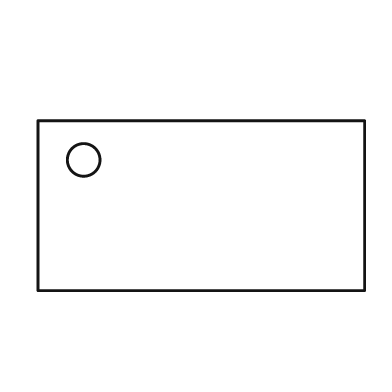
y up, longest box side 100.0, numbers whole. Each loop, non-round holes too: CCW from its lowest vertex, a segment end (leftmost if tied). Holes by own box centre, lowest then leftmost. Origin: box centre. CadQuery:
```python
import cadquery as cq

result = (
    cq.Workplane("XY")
    .moveTo(-50.0, -26.0)
    .lineTo(50.0, -26.0)
    .lineTo(50.0, 26.0)
    .lineTo(-50.0, 26.0)
    .close()
    .moveTo(-36.0, 14.0)
    .circle(5.0)
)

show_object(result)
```